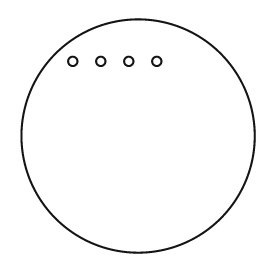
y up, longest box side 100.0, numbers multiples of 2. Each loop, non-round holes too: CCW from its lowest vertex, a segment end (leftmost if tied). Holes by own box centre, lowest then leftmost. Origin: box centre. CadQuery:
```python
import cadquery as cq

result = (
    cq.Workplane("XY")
    .moveTo(0.0, 0.0)
    .circle(50.0)
    .moveTo(-28.0, 32.0)
    .circle(2.0)
    .moveTo(-16.0, 32.0)
    .circle(2.0)
    .moveTo(-4.0, 32.0)
    .circle(2.0)
    .moveTo(8.0, 32.0)
    .circle(2.0)
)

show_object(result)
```